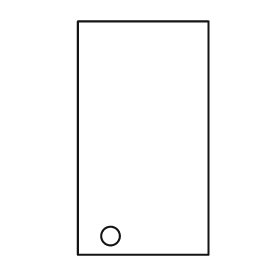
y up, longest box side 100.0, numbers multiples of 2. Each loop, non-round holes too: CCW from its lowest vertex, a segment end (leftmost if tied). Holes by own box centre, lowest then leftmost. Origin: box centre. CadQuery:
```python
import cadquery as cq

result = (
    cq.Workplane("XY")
    .moveTo(-28.0, -50.0)
    .lineTo(28.0, -50.0)
    .lineTo(28.0, 50.0)
    .lineTo(-28.0, 50.0)
    .close()
    .moveTo(-14.0, -42.0)
    .circle(4.0)
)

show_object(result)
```